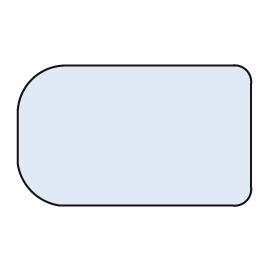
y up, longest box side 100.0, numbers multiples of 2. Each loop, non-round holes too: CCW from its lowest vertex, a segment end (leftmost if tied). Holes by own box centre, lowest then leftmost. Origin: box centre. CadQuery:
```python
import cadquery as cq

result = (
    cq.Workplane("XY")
    .moveTo(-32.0, -30.0)
    .lineTo(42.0, -30.0)
    .threePointArc((48.0, -28.0), (50.0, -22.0))
    .lineTo(50.0, 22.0)
    .threePointArc((48.0, 28.0), (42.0, 30.0))
    .lineTo(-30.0, 30.0)
    .threePointArc((-44.0, 24.0), (-50.0, 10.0))
    .lineTo(-50.0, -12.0)
    .threePointArc((-44.0, -24.0), (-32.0, -30.0))
    .close()
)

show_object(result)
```